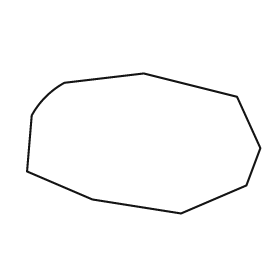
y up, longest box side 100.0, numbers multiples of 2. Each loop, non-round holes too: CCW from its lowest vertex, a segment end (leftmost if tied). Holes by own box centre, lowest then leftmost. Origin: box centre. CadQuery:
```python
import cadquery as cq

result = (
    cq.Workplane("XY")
    .moveTo(16.0, -30.0)
    .lineTo(44.0, -18.0)
    .lineTo(50.0, -2.0)
    .lineTo(40.0, 20.0)
    .lineTo(0.0, 30.0)
    .lineTo(-34.0, 26.0)
    .threePointArc((-42.0, 20.0), (-48.0, 12.0))
    .lineTo(-50.0, -12.0)
    .lineTo(-22.0, -24.0)
    .close()
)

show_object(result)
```